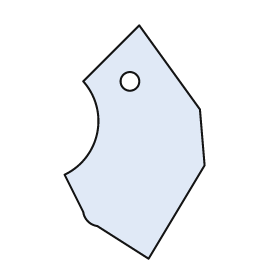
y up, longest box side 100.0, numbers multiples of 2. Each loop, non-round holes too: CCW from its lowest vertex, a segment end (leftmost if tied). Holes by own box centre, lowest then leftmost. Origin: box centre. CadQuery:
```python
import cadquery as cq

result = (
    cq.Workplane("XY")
    .moveTo(6.0, -50.0)
    .lineTo(30.0, -10.0)
    .lineTo(28.0, 14.0)
    .lineTo(2.0, 50.0)
    .lineTo(-22.0, 26.0)
    .threePointArc((-16.0, 4.0), (-30.0, -14.0))
    .lineTo(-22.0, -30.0)
    .threePointArc((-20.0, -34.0), (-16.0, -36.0))
    .close()
    .moveTo(-2.0, 26.0)
    .circle(4.0)
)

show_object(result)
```